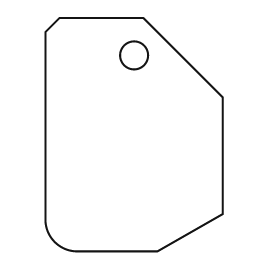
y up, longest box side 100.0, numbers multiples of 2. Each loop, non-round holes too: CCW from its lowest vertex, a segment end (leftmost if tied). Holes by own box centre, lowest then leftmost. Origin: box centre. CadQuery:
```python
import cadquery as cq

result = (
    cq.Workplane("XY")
    .moveTo(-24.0, -50.0)
    .lineTo(10.0, -50.0)
    .lineTo(38.0, -34.0)
    .lineTo(38.0, 16.0)
    .lineTo(4.0, 50.0)
    .lineTo(-32.0, 50.0)
    .lineTo(-38.0, 44.0)
    .lineTo(-38.0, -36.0)
    .threePointArc((-34.0, -46.0), (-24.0, -50.0))
    .close()
    .moveTo(0.0, 34.0)
    .circle(6.0)
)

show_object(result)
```